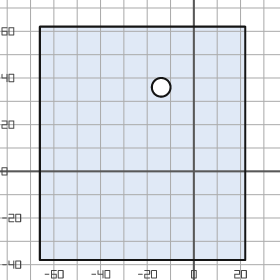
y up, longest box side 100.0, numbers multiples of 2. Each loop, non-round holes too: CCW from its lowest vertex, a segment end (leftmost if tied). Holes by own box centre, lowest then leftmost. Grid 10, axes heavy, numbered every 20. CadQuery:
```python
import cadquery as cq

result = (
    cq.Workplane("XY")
    .moveTo(-66.0, -38.0)
    .lineTo(22.0, -38.0)
    .lineTo(22.0, 62.0)
    .lineTo(-66.0, 62.0)
    .close()
    .moveTo(-14.0, 36.0)
    .circle(4.0)
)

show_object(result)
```